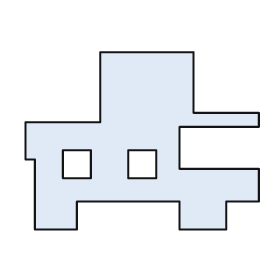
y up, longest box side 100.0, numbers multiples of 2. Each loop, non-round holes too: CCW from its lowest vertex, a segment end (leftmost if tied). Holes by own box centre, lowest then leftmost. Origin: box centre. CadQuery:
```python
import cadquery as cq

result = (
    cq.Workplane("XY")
    .moveTo(-46.0, -38.0)
    .lineTo(-28.0, -38.0)
    .lineTo(-28.0, -26.0)
    .lineTo(16.0, -26.0)
    .lineTo(16.0, -38.0)
    .lineTo(36.0, -38.0)
    .lineTo(36.0, -26.0)
    .lineTo(50.0, -26.0)
    .lineTo(50.0, -12.0)
    .lineTo(16.0, -12.0)
    .lineTo(16.0, 6.0)
    .lineTo(50.0, 6.0)
    .lineTo(50.0, 12.0)
    .lineTo(22.0, 12.0)
    .lineTo(22.0, 38.0)
    .lineTo(-18.0, 38.0)
    .lineTo(-18.0, 8.0)
    .lineTo(-50.0, 8.0)
    .lineTo(-50.0, -8.0)
    .lineTo(-46.0, -8.0)
    .close()
    .moveTo(-34.0, -16.0)
    .lineTo(-22.0, -16.0)
    .lineTo(-22.0, -4.0)
    .lineTo(-34.0, -4.0)
    .close()
    .moveTo(-6.0, -16.0)
    .lineTo(6.0, -16.0)
    .lineTo(6.0, -4.0)
    .lineTo(-6.0, -4.0)
    .close()
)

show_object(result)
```